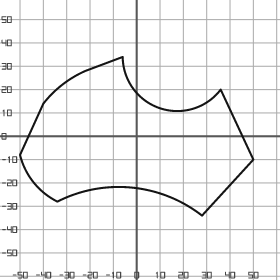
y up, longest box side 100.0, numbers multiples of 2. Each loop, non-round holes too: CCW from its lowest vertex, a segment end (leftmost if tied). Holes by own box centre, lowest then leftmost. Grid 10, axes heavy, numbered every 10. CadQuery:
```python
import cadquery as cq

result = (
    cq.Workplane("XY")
    .moveTo(28.0, -34.0)
    .lineTo(50.0, -10.0)
    .lineTo(36.0, 20.0)
    .threePointArc((10.0, 12.0), (-6.0, 34.0))
    .lineTo(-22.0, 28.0)
    .threePointArc((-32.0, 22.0), (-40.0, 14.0))
    .lineTo(-50.0, -8.0)
    .threePointArc((-44.0, -20.0), (-34.0, -28.0))
    .threePointArc((-2.0, -22.0), (28.0, -34.0))
    .close()
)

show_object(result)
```